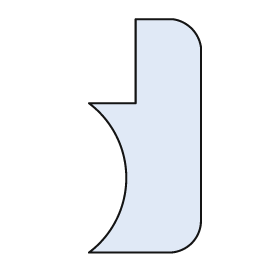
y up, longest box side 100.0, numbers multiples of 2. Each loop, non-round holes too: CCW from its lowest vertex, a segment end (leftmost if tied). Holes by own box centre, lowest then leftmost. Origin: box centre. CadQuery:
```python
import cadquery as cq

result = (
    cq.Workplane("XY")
    .moveTo(-24.0, -50.0)
    .lineTo(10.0, -50.0)
    .threePointArc((20.0, -46.0), (24.0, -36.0))
    .lineTo(24.0, 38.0)
    .threePointArc((20.0, 46.0), (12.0, 50.0))
    .lineTo(-4.0, 50.0)
    .lineTo(-4.0, 14.0)
    .lineTo(-24.0, 14.0)
    .threePointArc((-8.0, -18.0), (-24.0, -50.0))
    .close()
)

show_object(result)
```